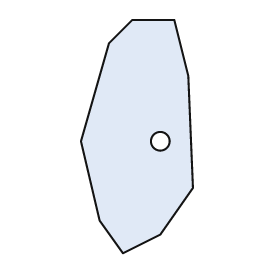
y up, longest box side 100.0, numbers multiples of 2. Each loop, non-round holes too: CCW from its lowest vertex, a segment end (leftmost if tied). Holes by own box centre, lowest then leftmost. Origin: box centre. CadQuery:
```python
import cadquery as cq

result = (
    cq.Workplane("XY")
    .moveTo(-6.0, -50.0)
    .lineTo(10.0, -42.0)
    .lineTo(24.0, -22.0)
    .lineTo(22.0, 26.0)
    .lineTo(16.0, 50.0)
    .lineTo(-2.0, 50.0)
    .lineTo(-12.0, 40.0)
    .lineTo(-24.0, -2.0)
    .lineTo(-16.0, -36.0)
    .close()
    .moveTo(10.0, -2.0)
    .circle(4.0)
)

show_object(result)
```